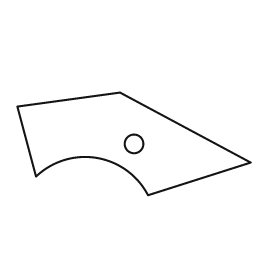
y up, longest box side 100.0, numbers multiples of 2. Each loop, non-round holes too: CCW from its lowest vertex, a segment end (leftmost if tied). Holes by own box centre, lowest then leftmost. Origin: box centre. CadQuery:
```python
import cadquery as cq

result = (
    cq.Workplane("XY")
    .moveTo(6.0, -22.0)
    .lineTo(50.0, -8.0)
    .lineTo(-6.0, 22.0)
    .lineTo(-50.0, 16.0)
    .lineTo(-42.0, -14.0)
    .threePointArc((-16.0, -6.0), (6.0, -22.0))
    .close()
    .moveTo(0.0, 0.0)
    .circle(4.0)
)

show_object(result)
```